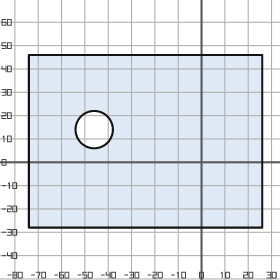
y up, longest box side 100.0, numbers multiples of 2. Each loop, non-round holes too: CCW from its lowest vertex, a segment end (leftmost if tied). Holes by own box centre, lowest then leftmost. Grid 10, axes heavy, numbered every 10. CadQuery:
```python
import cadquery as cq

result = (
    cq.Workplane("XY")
    .moveTo(-74.0, -28.0)
    .lineTo(26.0, -28.0)
    .lineTo(26.0, 46.0)
    .lineTo(-74.0, 46.0)
    .close()
    .moveTo(-46.0, 14.0)
    .circle(8.0)
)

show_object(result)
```